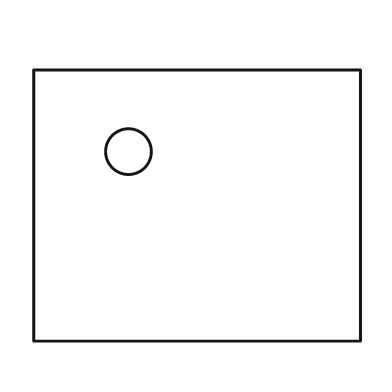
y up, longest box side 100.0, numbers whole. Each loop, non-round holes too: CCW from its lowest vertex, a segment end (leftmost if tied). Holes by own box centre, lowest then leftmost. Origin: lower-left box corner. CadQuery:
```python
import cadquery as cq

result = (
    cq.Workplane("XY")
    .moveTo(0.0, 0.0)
    .lineTo(100.0, 0.0)
    .lineTo(100.0, 83.0)
    .lineTo(0.0, 83.0)
    .close()
    .moveTo(29.0, 58.0)
    .circle(7.0)
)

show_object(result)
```